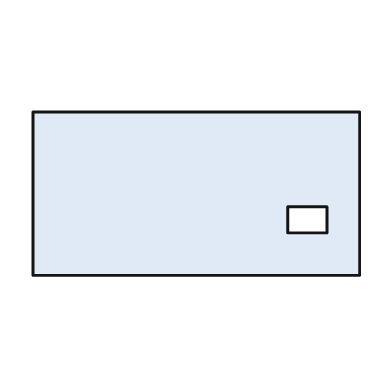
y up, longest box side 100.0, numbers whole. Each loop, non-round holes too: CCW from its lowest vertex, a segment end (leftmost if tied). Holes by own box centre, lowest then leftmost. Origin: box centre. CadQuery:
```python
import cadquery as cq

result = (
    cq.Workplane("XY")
    .moveTo(-50.0, -25.0)
    .lineTo(50.0, -25.0)
    .lineTo(50.0, 25.0)
    .lineTo(-50.0, 25.0)
    .close()
    .moveTo(28.0, -12.0)
    .lineTo(40.0, -12.0)
    .lineTo(40.0, -4.0)
    .lineTo(28.0, -4.0)
    .close()
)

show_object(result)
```